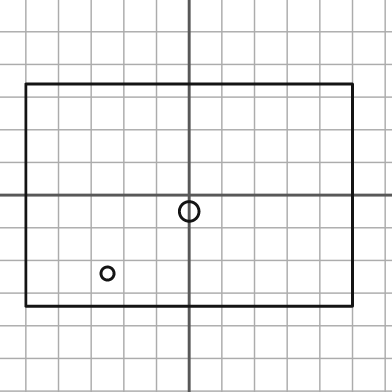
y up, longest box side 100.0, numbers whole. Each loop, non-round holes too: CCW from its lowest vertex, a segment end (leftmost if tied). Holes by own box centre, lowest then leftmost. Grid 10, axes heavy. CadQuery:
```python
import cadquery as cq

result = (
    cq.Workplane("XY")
    .moveTo(-50.0, -34.0)
    .lineTo(50.0, -34.0)
    .lineTo(50.0, 34.0)
    .lineTo(-50.0, 34.0)
    .close()
    .moveTo(-25.0, -24.0)
    .circle(2.0)
    .moveTo(0.0, -5.0)
    .circle(3.0)
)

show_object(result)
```